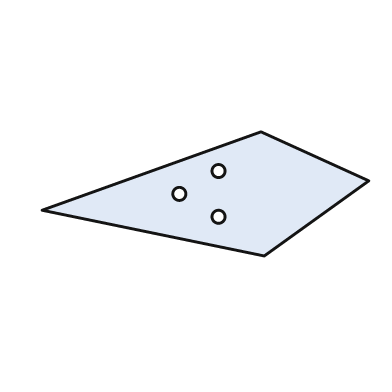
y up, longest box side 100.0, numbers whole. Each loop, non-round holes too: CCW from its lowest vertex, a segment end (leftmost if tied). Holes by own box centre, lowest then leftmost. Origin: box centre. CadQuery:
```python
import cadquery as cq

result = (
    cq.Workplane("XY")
    .moveTo(18.0, -19.0)
    .lineTo(50.0, 4.0)
    .lineTo(17.0, 19.0)
    .lineTo(-50.0, -5.0)
    .close()
    .moveTo(4.0, -7.0)
    .circle(2.0)
    .moveTo(-8.0, 0.0)
    .circle(2.0)
    .moveTo(4.0, 7.0)
    .circle(2.0)
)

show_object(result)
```